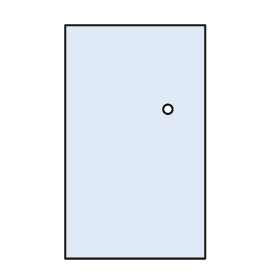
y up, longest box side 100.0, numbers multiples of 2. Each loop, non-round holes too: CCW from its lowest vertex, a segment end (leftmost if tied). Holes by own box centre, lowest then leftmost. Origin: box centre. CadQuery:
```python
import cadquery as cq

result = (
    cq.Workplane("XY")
    .moveTo(-30.0, -50.0)
    .lineTo(30.0, -50.0)
    .lineTo(30.0, 50.0)
    .lineTo(-30.0, 50.0)
    .close()
    .moveTo(14.0, 14.0)
    .circle(2.0)
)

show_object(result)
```